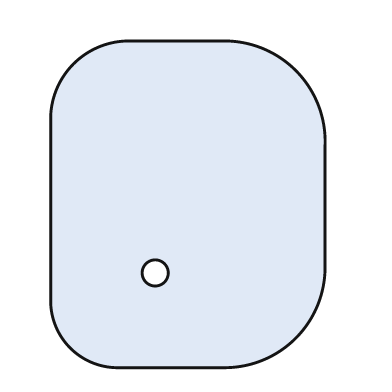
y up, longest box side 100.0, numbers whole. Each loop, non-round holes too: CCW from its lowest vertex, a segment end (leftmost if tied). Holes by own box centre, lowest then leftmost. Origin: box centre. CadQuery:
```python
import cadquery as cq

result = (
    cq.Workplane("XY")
    .moveTo(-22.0, -50.0)
    .lineTo(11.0, -50.0)
    .threePointArc((33.0, -41.0), (42.0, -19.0))
    .lineTo(42.0, 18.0)
    .threePointArc((33.0, 41.0), (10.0, 50.0))
    .lineTo(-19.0, 50.0)
    .threePointArc((-35.0, 43.0), (-42.0, 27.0))
    .lineTo(-42.0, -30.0)
    .threePointArc((-36.0, -44.0), (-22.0, -50.0))
    .close()
    .moveTo(-10.0, -21.0)
    .circle(4.0)
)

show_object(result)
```